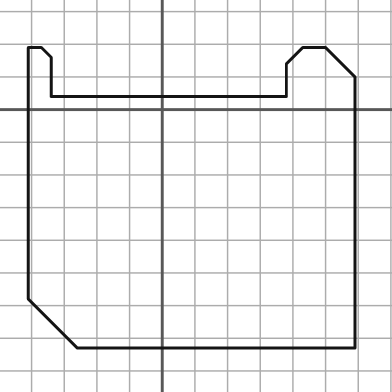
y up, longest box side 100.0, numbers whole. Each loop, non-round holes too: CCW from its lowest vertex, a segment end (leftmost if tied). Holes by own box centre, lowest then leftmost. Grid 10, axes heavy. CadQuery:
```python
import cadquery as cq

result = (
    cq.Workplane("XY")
    .moveTo(-26.0, -73.0)
    .lineTo(59.0, -73.0)
    .lineTo(59.0, 10.0)
    .lineTo(50.0, 19.0)
    .lineTo(43.0, 19.0)
    .lineTo(38.0, 14.0)
    .lineTo(38.0, 4.0)
    .lineTo(-34.0, 4.0)
    .lineTo(-34.0, 16.0)
    .lineTo(-37.0, 19.0)
    .lineTo(-41.0, 19.0)
    .lineTo(-41.0, -58.0)
    .close()
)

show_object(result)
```